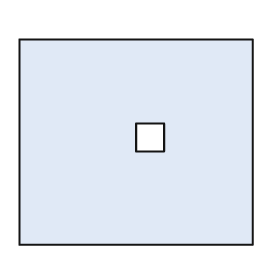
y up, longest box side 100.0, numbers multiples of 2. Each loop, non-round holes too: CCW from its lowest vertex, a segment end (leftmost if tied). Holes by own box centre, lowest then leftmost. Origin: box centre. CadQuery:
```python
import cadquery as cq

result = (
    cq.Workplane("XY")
    .moveTo(-50.0, -44.0)
    .lineTo(50.0, -44.0)
    .lineTo(50.0, 44.0)
    .lineTo(-50.0, 44.0)
    .close()
    .moveTo(0.0, -4.0)
    .lineTo(12.0, -4.0)
    .lineTo(12.0, 8.0)
    .lineTo(0.0, 8.0)
    .close()
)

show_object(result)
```